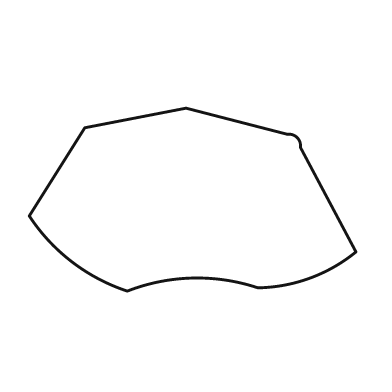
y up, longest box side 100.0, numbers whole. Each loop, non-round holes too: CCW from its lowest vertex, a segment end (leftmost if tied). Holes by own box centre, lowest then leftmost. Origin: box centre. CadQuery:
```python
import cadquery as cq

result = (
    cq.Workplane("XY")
    .moveTo(-20.0, -28.0)
    .threePointArc((0.0, -24.0), (20.0, -27.0))
    .threePointArc((36.0, -24.0), (50.0, -16.0))
    .lineTo(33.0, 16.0)
    .threePointArc((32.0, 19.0), (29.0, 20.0))
    .lineTo(-2.0, 28.0)
    .lineTo(-33.0, 22.0)
    .lineTo(-50.0, -5.0)
    .threePointArc((-37.0, -19.0), (-20.0, -28.0))
    .close()
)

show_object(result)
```